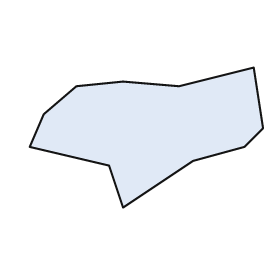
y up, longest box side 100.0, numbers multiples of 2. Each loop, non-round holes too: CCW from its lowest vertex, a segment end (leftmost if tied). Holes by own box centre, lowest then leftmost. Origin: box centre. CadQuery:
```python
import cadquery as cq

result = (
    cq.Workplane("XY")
    .moveTo(-10.0, -30.0)
    .lineTo(20.0, -10.0)
    .lineTo(42.0, -4.0)
    .lineTo(50.0, 4.0)
    .lineTo(46.0, 30.0)
    .lineTo(14.0, 22.0)
    .lineTo(-10.0, 24.0)
    .lineTo(-30.0, 22.0)
    .lineTo(-44.0, 10.0)
    .lineTo(-50.0, -4.0)
    .lineTo(-16.0, -12.0)
    .close()
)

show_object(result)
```